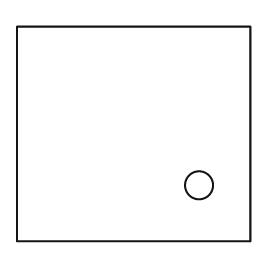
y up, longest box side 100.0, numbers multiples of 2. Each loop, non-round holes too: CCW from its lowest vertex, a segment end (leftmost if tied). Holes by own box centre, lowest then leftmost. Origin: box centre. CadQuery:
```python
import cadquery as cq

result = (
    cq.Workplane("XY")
    .moveTo(-50.0, -46.0)
    .lineTo(50.0, -46.0)
    .lineTo(50.0, 46.0)
    .lineTo(-50.0, 46.0)
    .close()
    .moveTo(28.0, -22.0)
    .circle(6.0)
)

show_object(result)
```